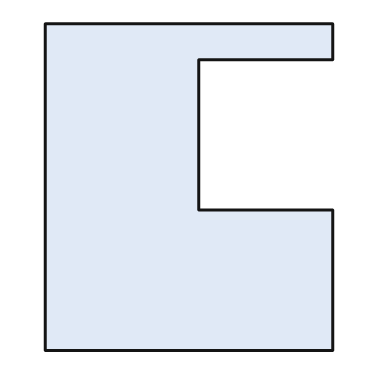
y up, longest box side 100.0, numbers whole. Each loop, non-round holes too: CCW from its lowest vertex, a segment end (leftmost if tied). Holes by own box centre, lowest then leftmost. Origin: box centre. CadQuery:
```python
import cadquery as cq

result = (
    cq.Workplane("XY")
    .moveTo(-44.0, -50.0)
    .lineTo(44.0, -50.0)
    .lineTo(44.0, -7.0)
    .lineTo(3.0, -7.0)
    .lineTo(3.0, 39.0)
    .lineTo(44.0, 39.0)
    .lineTo(44.0, 50.0)
    .lineTo(-44.0, 50.0)
    .close()
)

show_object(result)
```